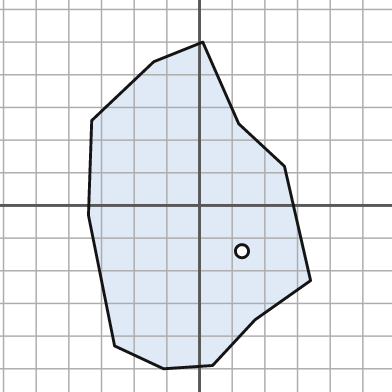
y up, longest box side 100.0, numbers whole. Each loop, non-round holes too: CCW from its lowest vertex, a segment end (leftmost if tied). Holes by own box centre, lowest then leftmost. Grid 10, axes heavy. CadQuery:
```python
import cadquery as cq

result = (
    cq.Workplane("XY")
    .moveTo(-11.0, -50.0)
    .lineTo(4.0, -49.0)
    .lineTo(17.0, -35.0)
    .lineTo(34.0, -23.0)
    .lineTo(26.0, 12.0)
    .lineTo(12.0, 25.0)
    .lineTo(1.0, 50.0)
    .lineTo(-14.0, 44.0)
    .lineTo(-33.0, 26.0)
    .lineTo(-34.0, -3.0)
    .lineTo(-26.0, -43.0)
    .close()
    .moveTo(13.0, -14.0)
    .circle(2.0)
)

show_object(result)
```